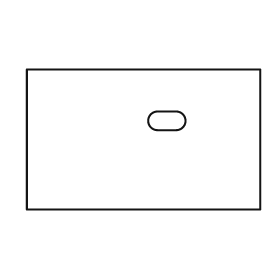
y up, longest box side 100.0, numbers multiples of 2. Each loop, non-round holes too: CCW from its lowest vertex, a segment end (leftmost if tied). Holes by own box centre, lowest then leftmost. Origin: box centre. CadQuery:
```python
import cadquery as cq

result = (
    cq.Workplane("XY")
    .moveTo(-50.0, -30.0)
    .lineTo(50.0, -30.0)
    .lineTo(50.0, 30.0)
    .lineTo(-50.0, 30.0)
    .close()
    .moveTo(6.0, 4.0)
    .lineTo(14.0, 4.0)
    .threePointArc((18.0, 8.0), (14.0, 12.0))
    .lineTo(6.0, 12.0)
    .threePointArc((2.0, 8.0), (6.0, 4.0))
    .close()
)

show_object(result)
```